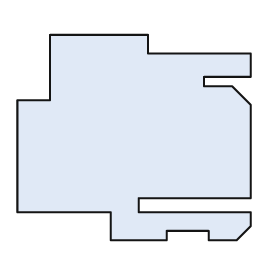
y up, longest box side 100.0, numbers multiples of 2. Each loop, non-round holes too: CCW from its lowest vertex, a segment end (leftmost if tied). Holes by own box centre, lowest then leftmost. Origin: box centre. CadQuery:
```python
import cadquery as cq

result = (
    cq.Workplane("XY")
    .moveTo(-10.0, -44.0)
    .lineTo(14.0, -44.0)
    .lineTo(14.0, -40.0)
    .lineTo(32.0, -40.0)
    .lineTo(32.0, -44.0)
    .lineTo(44.0, -44.0)
    .lineTo(50.0, -38.0)
    .lineTo(50.0, -32.0)
    .lineTo(2.0, -32.0)
    .lineTo(2.0, -26.0)
    .lineTo(50.0, -26.0)
    .lineTo(50.0, 14.0)
    .lineTo(42.0, 22.0)
    .lineTo(30.0, 22.0)
    .lineTo(30.0, 26.0)
    .lineTo(50.0, 26.0)
    .lineTo(50.0, 36.0)
    .lineTo(6.0, 36.0)
    .lineTo(6.0, 44.0)
    .lineTo(-36.0, 44.0)
    .lineTo(-36.0, 16.0)
    .lineTo(-50.0, 16.0)
    .lineTo(-50.0, -32.0)
    .lineTo(-10.0, -32.0)
    .close()
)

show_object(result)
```